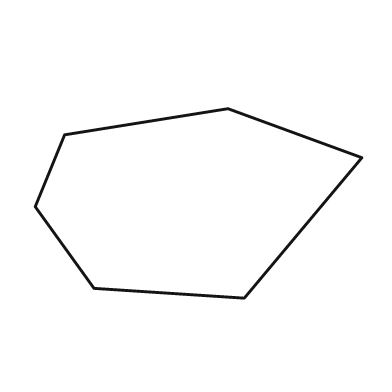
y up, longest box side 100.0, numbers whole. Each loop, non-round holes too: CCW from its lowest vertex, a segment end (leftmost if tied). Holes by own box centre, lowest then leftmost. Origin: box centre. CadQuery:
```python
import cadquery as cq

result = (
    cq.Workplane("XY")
    .moveTo(14.0, -29.0)
    .lineTo(50.0, 14.0)
    .lineTo(9.0, 29.0)
    .lineTo(-41.0, 21.0)
    .lineTo(-50.0, -1.0)
    .lineTo(-32.0, -26.0)
    .close()
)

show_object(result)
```